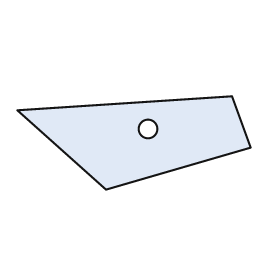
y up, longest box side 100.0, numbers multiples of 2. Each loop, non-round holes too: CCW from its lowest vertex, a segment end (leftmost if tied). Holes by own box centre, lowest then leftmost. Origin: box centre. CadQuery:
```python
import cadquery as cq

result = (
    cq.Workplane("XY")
    .moveTo(-12.0, -20.0)
    .lineTo(50.0, -2.0)
    .lineTo(42.0, 20.0)
    .lineTo(-50.0, 14.0)
    .close()
    .moveTo(6.0, 6.0)
    .circle(4.0)
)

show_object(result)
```